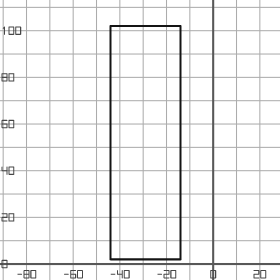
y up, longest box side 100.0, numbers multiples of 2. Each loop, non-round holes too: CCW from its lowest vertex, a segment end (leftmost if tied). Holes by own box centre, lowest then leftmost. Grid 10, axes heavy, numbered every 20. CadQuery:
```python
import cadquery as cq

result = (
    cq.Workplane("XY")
    .moveTo(-44.0, 2.0)
    .lineTo(-14.0, 2.0)
    .lineTo(-14.0, 102.0)
    .lineTo(-44.0, 102.0)
    .close()
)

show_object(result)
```